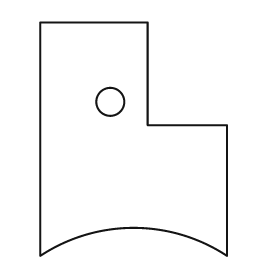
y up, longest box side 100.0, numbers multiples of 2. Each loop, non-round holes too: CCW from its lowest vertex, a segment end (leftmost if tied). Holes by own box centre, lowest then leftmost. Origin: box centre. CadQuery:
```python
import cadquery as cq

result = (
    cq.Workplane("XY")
    .moveTo(-40.0, -50.0)
    .threePointArc((0.0, -38.0), (40.0, -50.0))
    .lineTo(40.0, 6.0)
    .lineTo(6.0, 6.0)
    .lineTo(6.0, 50.0)
    .lineTo(-40.0, 50.0)
    .close()
    .moveTo(-10.0, 16.0)
    .circle(6.0)
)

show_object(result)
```